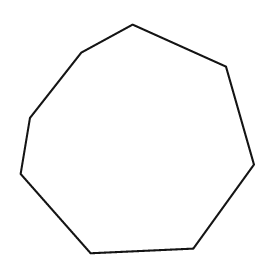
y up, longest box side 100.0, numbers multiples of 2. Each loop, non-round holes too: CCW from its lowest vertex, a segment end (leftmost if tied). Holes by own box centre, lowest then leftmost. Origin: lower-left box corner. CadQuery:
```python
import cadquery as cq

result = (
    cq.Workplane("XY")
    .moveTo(30.0, 0.0)
    .lineTo(74.0, 2.0)
    .lineTo(100.0, 38.0)
    .lineTo(88.0, 80.0)
    .lineTo(48.0, 98.0)
    .lineTo(26.0, 86.0)
    .lineTo(4.0, 58.0)
    .lineTo(0.0, 34.0)
    .close()
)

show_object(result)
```